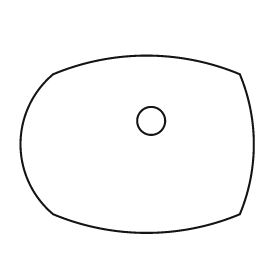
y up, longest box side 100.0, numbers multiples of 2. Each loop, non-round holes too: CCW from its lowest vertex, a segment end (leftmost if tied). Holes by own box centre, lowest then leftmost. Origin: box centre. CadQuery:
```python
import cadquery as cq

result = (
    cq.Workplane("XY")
    .moveTo(-36.0, -30.0)
    .threePointArc((4.0, -38.0), (44.0, -30.0))
    .threePointArc((50.0, 0.0), (44.0, 30.0))
    .threePointArc((4.0, 38.0), (-36.0, 30.0))
    .threePointArc((-50.0, 0.0), (-36.0, -30.0))
    .close()
    .moveTo(6.0, 10.0)
    .circle(6.0)
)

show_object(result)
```